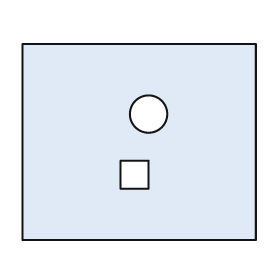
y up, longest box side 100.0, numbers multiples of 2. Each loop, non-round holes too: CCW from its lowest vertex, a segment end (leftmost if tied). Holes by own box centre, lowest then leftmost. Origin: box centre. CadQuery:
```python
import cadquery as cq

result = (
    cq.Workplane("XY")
    .moveTo(-50.0, -42.0)
    .lineTo(50.0, -42.0)
    .lineTo(50.0, 42.0)
    .lineTo(-50.0, 42.0)
    .close()
    .moveTo(-8.0, -20.0)
    .lineTo(4.0, -20.0)
    .lineTo(4.0, -8.0)
    .lineTo(-8.0, -8.0)
    .close()
    .moveTo(4.0, 12.0)
    .circle(8.0)
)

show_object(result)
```